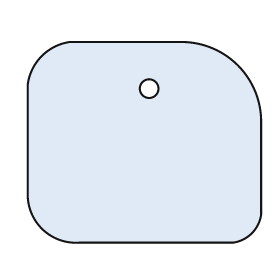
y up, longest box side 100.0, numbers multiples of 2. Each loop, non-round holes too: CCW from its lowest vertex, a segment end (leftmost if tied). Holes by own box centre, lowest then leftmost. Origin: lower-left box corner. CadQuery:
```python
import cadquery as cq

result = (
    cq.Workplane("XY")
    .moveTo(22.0, 0.0)
    .lineTo(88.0, 0.0)
    .threePointArc((96.0, 4.0), (100.0, 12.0))
    .lineTo(100.0, 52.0)
    .threePointArc((90.0, 76.0), (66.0, 86.0))
    .lineTo(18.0, 86.0)
    .threePointArc((6.0, 80.0), (0.0, 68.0))
    .lineTo(0.0, 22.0)
    .threePointArc((6.0, 6.0), (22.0, 0.0))
    .close()
    .moveTo(52.0, 66.0)
    .circle(4.0)
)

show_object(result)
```